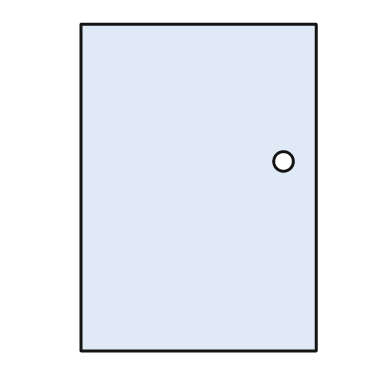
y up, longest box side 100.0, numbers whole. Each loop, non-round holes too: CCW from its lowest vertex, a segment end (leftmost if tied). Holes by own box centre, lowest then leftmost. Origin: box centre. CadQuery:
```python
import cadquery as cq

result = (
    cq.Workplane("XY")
    .moveTo(-36.0, -50.0)
    .lineTo(36.0, -50.0)
    .lineTo(36.0, 50.0)
    .lineTo(-36.0, 50.0)
    .close()
    .moveTo(26.0, 8.0)
    .circle(3.0)
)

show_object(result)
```